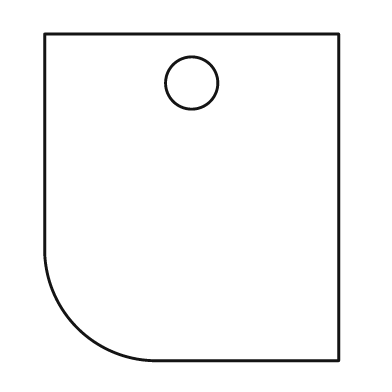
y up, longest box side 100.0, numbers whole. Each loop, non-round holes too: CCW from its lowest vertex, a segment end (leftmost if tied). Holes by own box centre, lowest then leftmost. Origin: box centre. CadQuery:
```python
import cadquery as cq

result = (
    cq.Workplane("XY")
    .moveTo(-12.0, -50.0)
    .lineTo(45.0, -50.0)
    .lineTo(45.0, 50.0)
    .lineTo(-45.0, 50.0)
    .lineTo(-45.0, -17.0)
    .threePointArc((-35.0, -40.0), (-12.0, -50.0))
    .close()
    .moveTo(0.0, 35.0)
    .circle(8.0)
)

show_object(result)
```